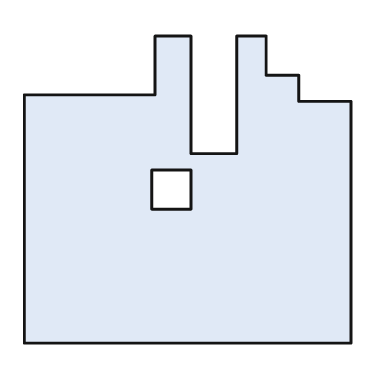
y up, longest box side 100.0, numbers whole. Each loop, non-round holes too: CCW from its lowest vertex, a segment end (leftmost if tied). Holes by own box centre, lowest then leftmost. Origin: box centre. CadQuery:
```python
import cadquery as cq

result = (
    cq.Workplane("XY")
    .moveTo(-50.0, -47.0)
    .lineTo(50.0, -47.0)
    .lineTo(50.0, 27.0)
    .lineTo(34.0, 27.0)
    .lineTo(34.0, 35.0)
    .lineTo(24.0, 35.0)
    .lineTo(24.0, 47.0)
    .lineTo(15.0, 47.0)
    .lineTo(15.0, 11.0)
    .lineTo(1.0, 11.0)
    .lineTo(1.0, 47.0)
    .lineTo(-10.0, 47.0)
    .lineTo(-10.0, 29.0)
    .lineTo(-50.0, 29.0)
    .close()
    .moveTo(-11.0, -6.0)
    .lineTo(1.0, -6.0)
    .lineTo(1.0, 6.0)
    .lineTo(-11.0, 6.0)
    .close()
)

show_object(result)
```